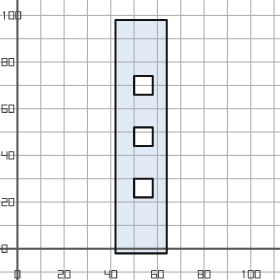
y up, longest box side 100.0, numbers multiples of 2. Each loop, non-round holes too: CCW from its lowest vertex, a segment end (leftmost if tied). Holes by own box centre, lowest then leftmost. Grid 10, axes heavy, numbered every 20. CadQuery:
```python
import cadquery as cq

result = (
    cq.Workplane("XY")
    .moveTo(42.0, -2.0)
    .lineTo(64.0, -2.0)
    .lineTo(64.0, 98.0)
    .lineTo(42.0, 98.0)
    .close()
    .moveTo(50.0, 22.0)
    .lineTo(58.0, 22.0)
    .lineTo(58.0, 30.0)
    .lineTo(50.0, 30.0)
    .close()
    .moveTo(50.0, 44.0)
    .lineTo(58.0, 44.0)
    .lineTo(58.0, 52.0)
    .lineTo(50.0, 52.0)
    .close()
    .moveTo(50.0, 66.0)
    .lineTo(58.0, 66.0)
    .lineTo(58.0, 74.0)
    .lineTo(50.0, 74.0)
    .close()
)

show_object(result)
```